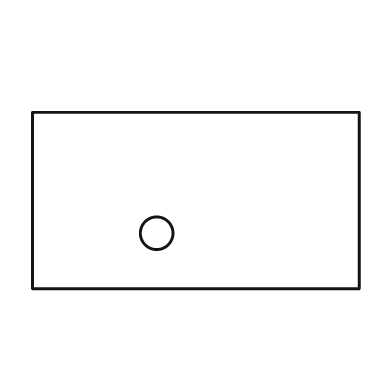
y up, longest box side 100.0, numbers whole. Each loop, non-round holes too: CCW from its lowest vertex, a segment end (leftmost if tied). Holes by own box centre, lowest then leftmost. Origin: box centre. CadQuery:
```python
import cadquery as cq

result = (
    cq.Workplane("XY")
    .moveTo(-50.0, -27.0)
    .lineTo(50.0, -27.0)
    .lineTo(50.0, 27.0)
    .lineTo(-50.0, 27.0)
    .close()
    .moveTo(-12.0, -10.0)
    .circle(5.0)
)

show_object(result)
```